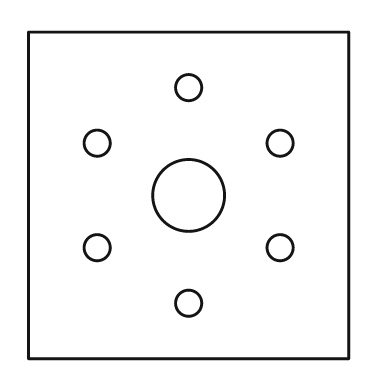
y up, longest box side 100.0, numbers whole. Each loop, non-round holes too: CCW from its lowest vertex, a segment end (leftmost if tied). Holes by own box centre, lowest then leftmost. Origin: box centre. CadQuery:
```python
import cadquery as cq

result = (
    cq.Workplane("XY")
    .moveTo(-49.0, -50.0)
    .lineTo(49.0, -50.0)
    .lineTo(49.0, 50.0)
    .lineTo(-49.0, 50.0)
    .close()
    .moveTo(0.0, -33.0)
    .circle(4.0)
    .moveTo(-28.0, -16.0)
    .circle(4.0)
    .moveTo(28.0, -16.0)
    .circle(4.0)
    .moveTo(0.0, 0.0)
    .circle(11.0)
    .moveTo(-28.0, 16.0)
    .circle(4.0)
    .moveTo(28.0, 16.0)
    .circle(4.0)
    .moveTo(0.0, 33.0)
    .circle(4.0)
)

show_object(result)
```